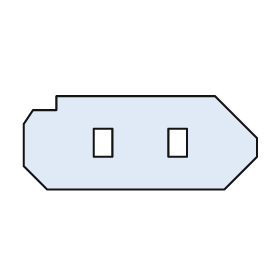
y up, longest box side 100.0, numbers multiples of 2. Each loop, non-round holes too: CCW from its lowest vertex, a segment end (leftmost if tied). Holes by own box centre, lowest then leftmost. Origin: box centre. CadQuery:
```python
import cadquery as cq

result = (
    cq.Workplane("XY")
    .moveTo(-40.0, -20.0)
    .lineTo(36.0, -20.0)
    .lineTo(50.0, -6.0)
    .lineTo(50.0, 2.0)
    .lineTo(32.0, 20.0)
    .lineTo(-36.0, 20.0)
    .lineTo(-36.0, 14.0)
    .lineTo(-46.0, 14.0)
    .lineTo(-50.0, 8.0)
    .lineTo(-50.0, -10.0)
    .close()
    .moveTo(-20.0, -6.0)
    .lineTo(-12.0, -6.0)
    .lineTo(-12.0, 6.0)
    .lineTo(-20.0, 6.0)
    .close()
    .moveTo(12.0, -6.0)
    .lineTo(20.0, -6.0)
    .lineTo(20.0, 6.0)
    .lineTo(12.0, 6.0)
    .close()
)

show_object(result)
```